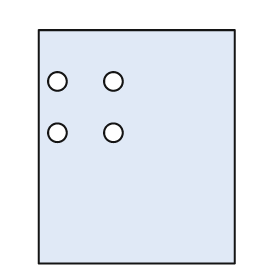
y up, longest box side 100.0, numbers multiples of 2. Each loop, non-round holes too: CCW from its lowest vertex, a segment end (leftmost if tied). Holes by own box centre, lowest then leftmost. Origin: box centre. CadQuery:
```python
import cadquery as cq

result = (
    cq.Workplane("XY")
    .moveTo(-42.0, -50.0)
    .lineTo(42.0, -50.0)
    .lineTo(42.0, 50.0)
    .lineTo(-42.0, 50.0)
    .close()
    .moveTo(-34.0, 6.0)
    .circle(4.0)
    .moveTo(-10.0, 6.0)
    .circle(4.0)
    .moveTo(-34.0, 28.0)
    .circle(4.0)
    .moveTo(-10.0, 28.0)
    .circle(4.0)
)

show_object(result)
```